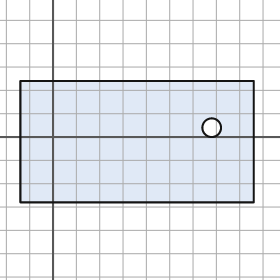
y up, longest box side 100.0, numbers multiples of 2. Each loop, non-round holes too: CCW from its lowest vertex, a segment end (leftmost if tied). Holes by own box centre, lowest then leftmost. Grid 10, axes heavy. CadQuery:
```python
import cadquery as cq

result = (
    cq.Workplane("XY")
    .moveTo(-14.0, -28.0)
    .lineTo(86.0, -28.0)
    .lineTo(86.0, 24.0)
    .lineTo(-14.0, 24.0)
    .close()
    .moveTo(68.0, 4.0)
    .circle(4.0)
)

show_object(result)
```